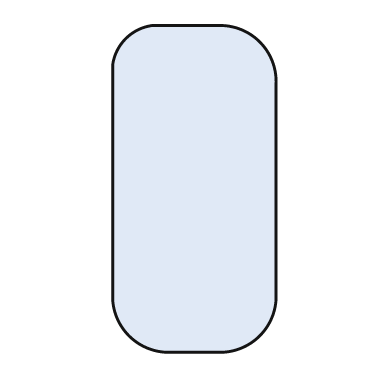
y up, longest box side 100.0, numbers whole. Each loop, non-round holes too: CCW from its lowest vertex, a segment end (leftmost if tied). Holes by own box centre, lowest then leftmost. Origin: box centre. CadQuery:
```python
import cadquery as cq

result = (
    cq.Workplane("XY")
    .moveTo(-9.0, -50.0)
    .lineTo(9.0, -50.0)
    .threePointArc((20.0, -45.0), (25.0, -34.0))
    .lineTo(25.0, 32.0)
    .threePointArc((20.0, 45.0), (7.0, 50.0))
    .lineTo(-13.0, 50.0)
    .threePointArc((-21.0, 46.0), (-25.0, 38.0))
    .lineTo(-25.0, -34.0)
    .threePointArc((-20.0, -45.0), (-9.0, -50.0))
    .close()
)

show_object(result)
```